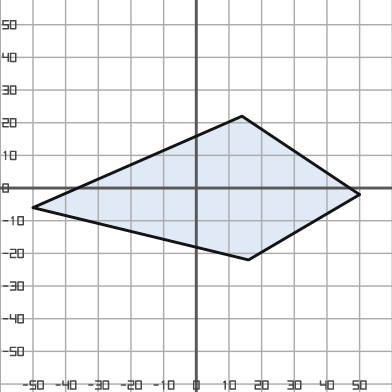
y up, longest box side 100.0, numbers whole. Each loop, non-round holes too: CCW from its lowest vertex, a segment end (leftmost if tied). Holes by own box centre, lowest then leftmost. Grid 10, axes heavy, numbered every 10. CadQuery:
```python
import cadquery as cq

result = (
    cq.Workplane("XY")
    .moveTo(16.0, -22.0)
    .lineTo(50.0, -2.0)
    .lineTo(14.0, 22.0)
    .lineTo(-50.0, -6.0)
    .close()
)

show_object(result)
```